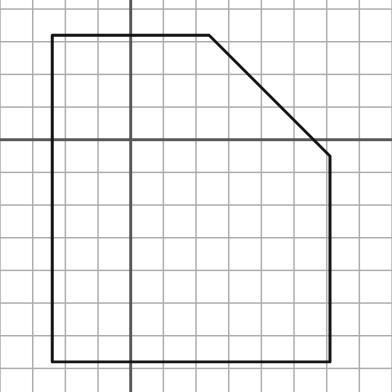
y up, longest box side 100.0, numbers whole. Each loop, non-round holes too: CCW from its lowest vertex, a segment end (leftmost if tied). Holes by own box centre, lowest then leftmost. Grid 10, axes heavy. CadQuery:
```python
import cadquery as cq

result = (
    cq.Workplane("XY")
    .moveTo(-24.0, -68.0)
    .lineTo(61.0, -68.0)
    .lineTo(61.0, -5.0)
    .lineTo(24.0, 32.0)
    .lineTo(-24.0, 32.0)
    .close()
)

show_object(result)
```